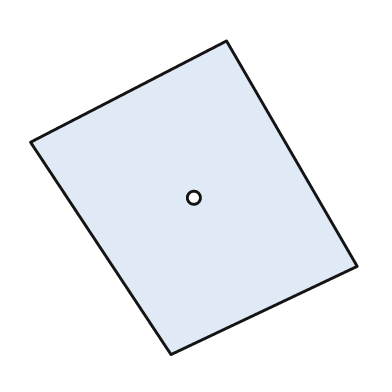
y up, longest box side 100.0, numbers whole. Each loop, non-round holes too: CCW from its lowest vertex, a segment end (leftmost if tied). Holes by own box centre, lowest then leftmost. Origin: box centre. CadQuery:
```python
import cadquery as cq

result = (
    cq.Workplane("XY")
    .moveTo(-7.0, -48.0)
    .lineTo(50.0, -21.0)
    .lineTo(10.0, 48.0)
    .lineTo(-50.0, 17.0)
    .close()
    .moveTo(0.0, 0.0)
    .circle(2.0)
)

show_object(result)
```